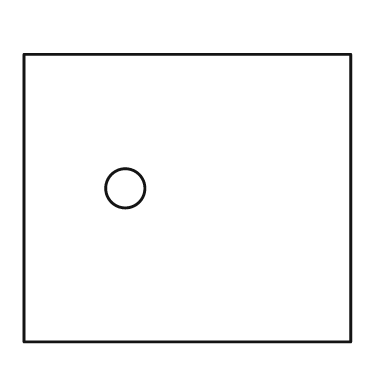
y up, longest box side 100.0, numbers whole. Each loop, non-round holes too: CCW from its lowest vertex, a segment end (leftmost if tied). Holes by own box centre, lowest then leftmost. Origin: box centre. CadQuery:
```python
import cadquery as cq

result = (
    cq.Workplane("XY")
    .moveTo(-50.0, -44.0)
    .lineTo(50.0, -44.0)
    .lineTo(50.0, 44.0)
    .lineTo(-50.0, 44.0)
    .close()
    .moveTo(-19.0, 3.0)
    .circle(6.0)
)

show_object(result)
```